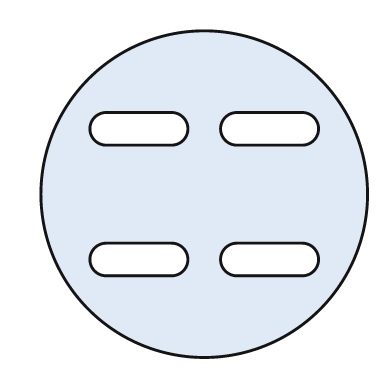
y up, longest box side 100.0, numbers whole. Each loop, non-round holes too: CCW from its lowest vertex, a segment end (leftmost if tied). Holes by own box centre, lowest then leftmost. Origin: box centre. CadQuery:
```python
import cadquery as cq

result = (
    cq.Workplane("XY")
    .moveTo(0.0, 0.0)
    .circle(50.0)
    .moveTo(-30.0, -25.0)
    .lineTo(-10.0, -25.0)
    .threePointArc((-5.0, -20.0), (-10.0, -15.0))
    .lineTo(-30.0, -15.0)
    .threePointArc((-35.0, -20.0), (-30.0, -25.0))
    .close()
    .moveTo(10.0, -25.0)
    .lineTo(30.0, -25.0)
    .threePointArc((35.0, -20.0), (30.0, -15.0))
    .lineTo(10.0, -15.0)
    .threePointArc((5.0, -20.0), (10.0, -25.0))
    .close()
    .moveTo(-30.0, 15.0)
    .lineTo(-10.0, 15.0)
    .threePointArc((-5.0, 20.0), (-10.0, 25.0))
    .lineTo(-30.0, 25.0)
    .threePointArc((-35.0, 20.0), (-30.0, 15.0))
    .close()
    .moveTo(10.0, 15.0)
    .lineTo(30.0, 15.0)
    .threePointArc((35.0, 20.0), (30.0, 25.0))
    .lineTo(10.0, 25.0)
    .threePointArc((5.0, 20.0), (10.0, 15.0))
    .close()
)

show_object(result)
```